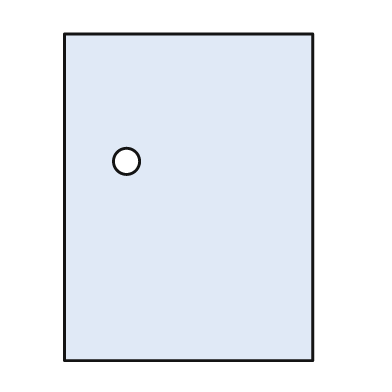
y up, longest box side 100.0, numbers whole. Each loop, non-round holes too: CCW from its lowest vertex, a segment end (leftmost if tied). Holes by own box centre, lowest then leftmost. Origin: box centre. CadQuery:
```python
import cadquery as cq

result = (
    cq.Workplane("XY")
    .moveTo(-38.0, -50.0)
    .lineTo(38.0, -50.0)
    .lineTo(38.0, 50.0)
    .lineTo(-38.0, 50.0)
    .close()
    .moveTo(-19.0, 11.0)
    .circle(4.0)
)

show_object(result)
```